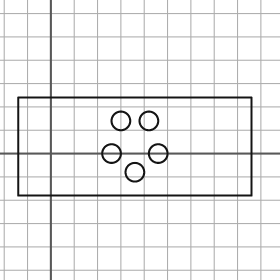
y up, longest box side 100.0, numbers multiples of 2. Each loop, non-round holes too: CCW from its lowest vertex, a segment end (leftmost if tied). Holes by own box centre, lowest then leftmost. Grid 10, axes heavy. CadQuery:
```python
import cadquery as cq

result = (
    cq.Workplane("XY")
    .moveTo(-14.0, -18.0)
    .lineTo(86.0, -18.0)
    .lineTo(86.0, 24.0)
    .lineTo(-14.0, 24.0)
    .close()
    .moveTo(36.0, -8.0)
    .circle(4.0)
    .moveTo(26.0, 0.0)
    .circle(4.0)
    .moveTo(46.0, 0.0)
    .circle(4.0)
    .moveTo(30.0, 14.0)
    .circle(4.0)
    .moveTo(42.0, 14.0)
    .circle(4.0)
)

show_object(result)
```